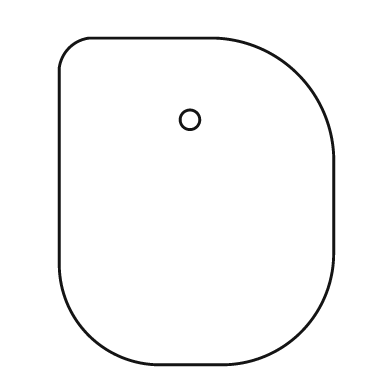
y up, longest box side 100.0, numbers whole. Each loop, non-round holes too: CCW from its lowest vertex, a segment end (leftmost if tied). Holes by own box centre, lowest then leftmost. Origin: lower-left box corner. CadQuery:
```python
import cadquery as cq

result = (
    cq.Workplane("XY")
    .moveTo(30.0, 0.0)
    .lineTo(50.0, 0.0)
    .threePointArc((74.0, 10.0), (84.0, 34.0))
    .lineTo(84.0, 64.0)
    .threePointArc((73.0, 89.0), (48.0, 100.0))
    .lineTo(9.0, 100.0)
    .threePointArc((3.0, 97.0), (0.0, 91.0))
    .lineTo(0.0, 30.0)
    .threePointArc((9.0, 9.0), (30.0, 0.0))
    .close()
    .moveTo(40.0, 75.0)
    .circle(3.0)
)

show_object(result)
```